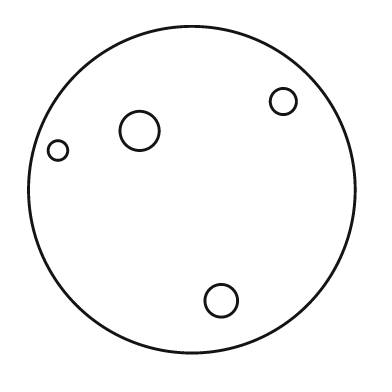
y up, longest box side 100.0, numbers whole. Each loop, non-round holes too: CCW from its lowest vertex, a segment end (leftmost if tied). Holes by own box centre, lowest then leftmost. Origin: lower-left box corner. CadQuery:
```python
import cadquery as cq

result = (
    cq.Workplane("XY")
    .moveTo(50.0, 50.0)
    .circle(50.0)
    .moveTo(59.0, 16.0)
    .circle(5.0)
    .moveTo(9.0, 62.0)
    .circle(3.0)
    .moveTo(34.0, 68.0)
    .circle(6.0)
    .moveTo(78.0, 77.0)
    .circle(4.0)
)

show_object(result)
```